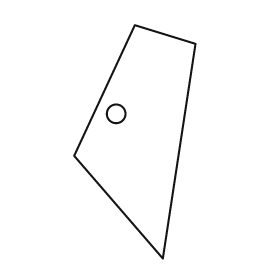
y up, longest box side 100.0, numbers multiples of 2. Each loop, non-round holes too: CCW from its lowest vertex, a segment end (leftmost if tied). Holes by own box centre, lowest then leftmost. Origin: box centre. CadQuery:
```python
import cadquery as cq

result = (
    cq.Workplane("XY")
    .moveTo(12.0, -50.0)
    .lineTo(26.0, 42.0)
    .lineTo(0.0, 50.0)
    .lineTo(-26.0, -6.0)
    .close()
    .moveTo(-8.0, 12.0)
    .circle(4.0)
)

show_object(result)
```